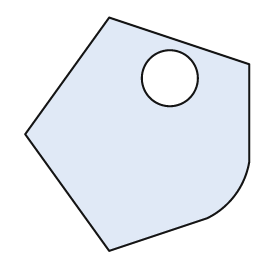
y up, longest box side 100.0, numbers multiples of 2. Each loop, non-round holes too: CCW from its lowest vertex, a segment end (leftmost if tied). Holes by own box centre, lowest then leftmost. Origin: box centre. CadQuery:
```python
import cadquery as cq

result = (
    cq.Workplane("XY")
    .moveTo(-12.0, -50.0)
    .lineTo(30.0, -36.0)
    .threePointArc((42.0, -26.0), (48.0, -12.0))
    .lineTo(48.0, 30.0)
    .lineTo(-12.0, 50.0)
    .lineTo(-48.0, 0.0)
    .close()
    .moveTo(14.0, 24.0)
    .circle(12.0)
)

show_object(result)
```